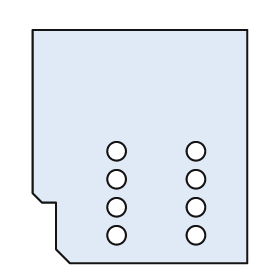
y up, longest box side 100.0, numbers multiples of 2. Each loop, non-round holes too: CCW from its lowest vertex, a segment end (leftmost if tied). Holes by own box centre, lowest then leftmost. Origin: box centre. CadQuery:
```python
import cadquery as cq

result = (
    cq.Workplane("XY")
    .moveTo(-30.0, -50.0)
    .lineTo(46.0, -50.0)
    .lineTo(46.0, 50.0)
    .lineTo(-46.0, 50.0)
    .lineTo(-46.0, -20.0)
    .lineTo(-42.0, -24.0)
    .lineTo(-36.0, -24.0)
    .lineTo(-36.0, -44.0)
    .close()
    .moveTo(-10.0, -38.0)
    .circle(4.0)
    .moveTo(24.0, -38.0)
    .circle(4.0)
    .moveTo(-10.0, -26.0)
    .circle(4.0)
    .moveTo(24.0, -26.0)
    .circle(4.0)
    .moveTo(-10.0, -14.0)
    .circle(4.0)
    .moveTo(24.0, -14.0)
    .circle(4.0)
    .moveTo(-10.0, -2.0)
    .circle(4.0)
    .moveTo(24.0, -2.0)
    .circle(4.0)
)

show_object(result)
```